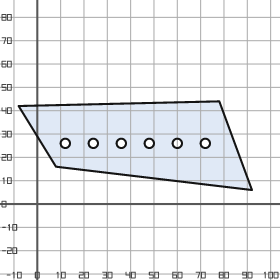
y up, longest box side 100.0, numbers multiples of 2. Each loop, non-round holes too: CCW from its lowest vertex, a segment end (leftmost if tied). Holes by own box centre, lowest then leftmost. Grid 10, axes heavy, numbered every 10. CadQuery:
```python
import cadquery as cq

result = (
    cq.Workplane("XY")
    .moveTo(92.0, 6.0)
    .lineTo(78.0, 44.0)
    .lineTo(-8.0, 42.0)
    .lineTo(8.0, 16.0)
    .close()
    .moveTo(12.0, 26.0)
    .circle(2.0)
    .moveTo(24.0, 26.0)
    .circle(2.0)
    .moveTo(36.0, 26.0)
    .circle(2.0)
    .moveTo(48.0, 26.0)
    .circle(2.0)
    .moveTo(60.0, 26.0)
    .circle(2.0)
    .moveTo(72.0, 26.0)
    .circle(2.0)
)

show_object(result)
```